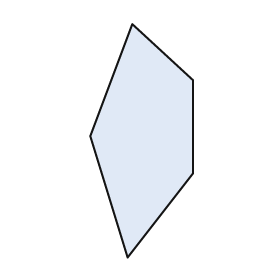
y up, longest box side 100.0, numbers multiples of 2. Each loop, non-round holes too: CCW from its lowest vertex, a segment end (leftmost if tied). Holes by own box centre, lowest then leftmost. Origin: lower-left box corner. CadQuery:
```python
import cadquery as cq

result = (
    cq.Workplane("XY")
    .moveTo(16.0, 0.0)
    .lineTo(44.0, 36.0)
    .lineTo(44.0, 76.0)
    .lineTo(18.0, 100.0)
    .lineTo(0.0, 52.0)
    .close()
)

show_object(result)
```